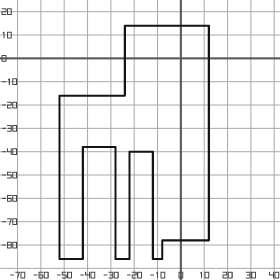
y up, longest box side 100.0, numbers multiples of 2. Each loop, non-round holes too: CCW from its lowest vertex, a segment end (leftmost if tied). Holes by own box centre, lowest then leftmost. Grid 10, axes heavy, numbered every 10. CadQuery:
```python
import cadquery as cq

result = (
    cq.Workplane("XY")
    .moveTo(-52.0, -86.0)
    .lineTo(-42.0, -86.0)
    .lineTo(-42.0, -38.0)
    .lineTo(-28.0, -38.0)
    .lineTo(-28.0, -86.0)
    .lineTo(-22.0, -86.0)
    .lineTo(-22.0, -40.0)
    .lineTo(-12.0, -40.0)
    .lineTo(-12.0, -86.0)
    .lineTo(-8.0, -86.0)
    .lineTo(-8.0, -78.0)
    .lineTo(12.0, -78.0)
    .lineTo(12.0, 14.0)
    .lineTo(-24.0, 14.0)
    .lineTo(-24.0, -16.0)
    .lineTo(-52.0, -16.0)
    .close()
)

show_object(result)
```